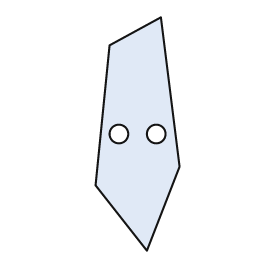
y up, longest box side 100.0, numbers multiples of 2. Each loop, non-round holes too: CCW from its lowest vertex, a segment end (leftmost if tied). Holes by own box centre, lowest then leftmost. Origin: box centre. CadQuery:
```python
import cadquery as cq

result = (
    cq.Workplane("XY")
    .moveTo(4.0, -50.0)
    .lineTo(18.0, -14.0)
    .lineTo(10.0, 50.0)
    .lineTo(-12.0, 38.0)
    .lineTo(-18.0, -22.0)
    .close()
    .moveTo(-8.0, 0.0)
    .circle(4.0)
    .moveTo(8.0, 0.0)
    .circle(4.0)
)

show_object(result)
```